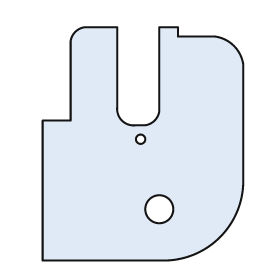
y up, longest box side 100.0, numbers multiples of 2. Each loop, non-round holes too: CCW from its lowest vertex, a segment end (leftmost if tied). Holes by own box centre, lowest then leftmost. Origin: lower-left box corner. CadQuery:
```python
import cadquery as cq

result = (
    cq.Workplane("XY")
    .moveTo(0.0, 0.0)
    .lineTo(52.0, 0.0)
    .threePointArc((76.0, 10.0), (86.0, 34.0))
    .lineTo(86.0, 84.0)
    .threePointArc((82.0, 92.0), (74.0, 96.0))
    .lineTo(58.0, 96.0)
    .lineTo(58.0, 100.0)
    .lineTo(50.0, 100.0)
    .lineTo(50.0, 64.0)
    .threePointArc((48.0, 60.0), (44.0, 58.0))
    .lineTo(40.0, 58.0)
    .threePointArc((34.0, 60.0), (32.0, 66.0))
    .lineTo(32.0, 100.0)
    .lineTo(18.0, 100.0)
    .threePointArc((14.0, 98.0), (12.0, 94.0))
    .lineTo(12.0, 60.0)
    .lineTo(0.0, 60.0)
    .close()
    .moveTo(50.0, 22.0)
    .circle(6.0)
    .moveTo(42.0, 52.0)
    .circle(2.0)
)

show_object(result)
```